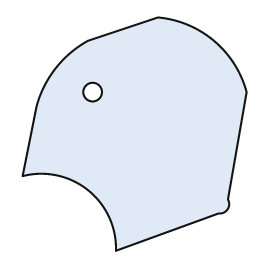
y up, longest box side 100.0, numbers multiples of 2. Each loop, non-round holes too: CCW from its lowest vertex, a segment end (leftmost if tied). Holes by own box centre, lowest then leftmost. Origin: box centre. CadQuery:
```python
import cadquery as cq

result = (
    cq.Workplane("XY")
    .moveTo(-8.0, -50.0)
    .lineTo(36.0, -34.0)
    .threePointArc((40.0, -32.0), (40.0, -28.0))
    .lineTo(48.0, 18.0)
    .threePointArc((34.0, 40.0), (10.0, 50.0))
    .lineTo(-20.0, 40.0)
    .threePointArc((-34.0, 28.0), (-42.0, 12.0))
    .lineTo(-48.0, -18.0)
    .threePointArc((-20.0, -24.0), (-8.0, -50.0))
    .close()
    .moveTo(-18.0, 18.0)
    .circle(4.0)
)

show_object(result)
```